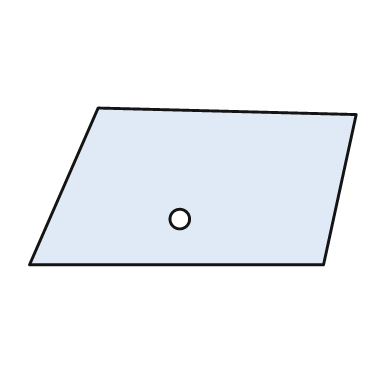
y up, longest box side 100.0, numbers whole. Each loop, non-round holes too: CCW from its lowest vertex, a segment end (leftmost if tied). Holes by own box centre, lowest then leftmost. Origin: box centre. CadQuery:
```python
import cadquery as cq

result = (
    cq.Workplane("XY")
    .moveTo(-50.0, -24.0)
    .lineTo(40.0, -24.0)
    .lineTo(50.0, 22.0)
    .lineTo(-29.0, 24.0)
    .close()
    .moveTo(-4.0, -10.0)
    .circle(3.0)
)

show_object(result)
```